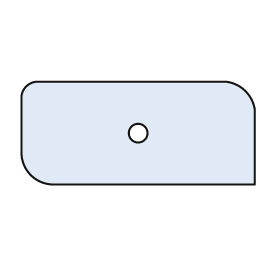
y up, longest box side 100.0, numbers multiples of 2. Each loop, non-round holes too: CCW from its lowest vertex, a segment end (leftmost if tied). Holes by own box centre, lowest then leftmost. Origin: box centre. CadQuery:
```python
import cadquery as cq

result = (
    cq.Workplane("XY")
    .moveTo(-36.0, -22.0)
    .lineTo(50.0, -22.0)
    .lineTo(50.0, 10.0)
    .threePointArc((46.0, 18.0), (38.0, 22.0))
    .lineTo(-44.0, 22.0)
    .threePointArc((-48.0, 20.0), (-50.0, 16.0))
    .lineTo(-50.0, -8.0)
    .threePointArc((-46.0, -18.0), (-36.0, -22.0))
    .close()
    .moveTo(0.0, 0.0)
    .circle(4.0)
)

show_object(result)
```